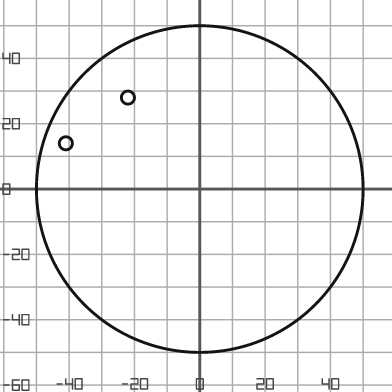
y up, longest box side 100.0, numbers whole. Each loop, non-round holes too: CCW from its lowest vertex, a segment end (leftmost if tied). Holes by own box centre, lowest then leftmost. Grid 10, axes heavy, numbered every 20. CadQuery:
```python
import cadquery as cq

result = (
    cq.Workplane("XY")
    .moveTo(0.0, 0.0)
    .circle(50.0)
    .moveTo(-41.0, 14.0)
    .circle(2.0)
    .moveTo(-22.0, 28.0)
    .circle(2.0)
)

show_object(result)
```